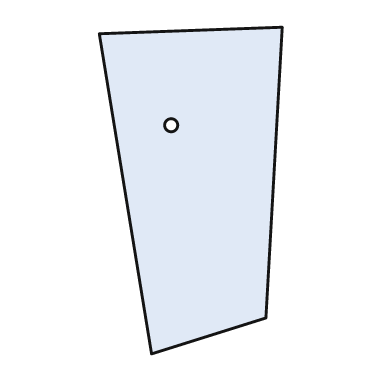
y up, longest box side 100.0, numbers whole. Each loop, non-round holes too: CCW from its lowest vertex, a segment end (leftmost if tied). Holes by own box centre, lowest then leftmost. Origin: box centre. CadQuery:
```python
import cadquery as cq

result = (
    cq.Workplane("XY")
    .moveTo(-12.0, -50.0)
    .lineTo(23.0, -39.0)
    .lineTo(28.0, 50.0)
    .lineTo(-28.0, 48.0)
    .close()
    .moveTo(-6.0, 20.0)
    .circle(2.0)
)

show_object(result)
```